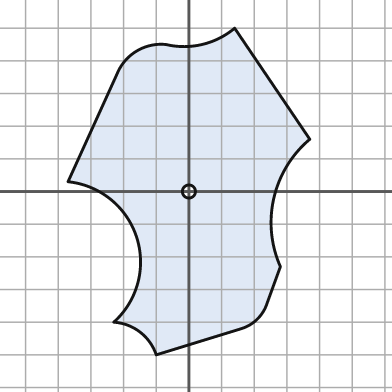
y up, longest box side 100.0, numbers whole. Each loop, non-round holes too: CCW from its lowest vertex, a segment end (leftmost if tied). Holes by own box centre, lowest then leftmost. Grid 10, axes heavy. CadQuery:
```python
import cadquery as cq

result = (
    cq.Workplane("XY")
    .moveTo(-10.0, -50.0)
    .lineTo(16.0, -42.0)
    .threePointArc((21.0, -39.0), (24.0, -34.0))
    .lineTo(28.0, -23.0)
    .threePointArc((26.0, -2.0), (37.0, 16.0))
    .lineTo(14.0, 50.0)
    .threePointArc((4.0, 45.0), (-7.0, 45.0))
    .threePointArc((-16.0, 43.0), (-22.0, 36.0))
    .lineTo(-37.0, 3.0)
    .threePointArc((-16.0, -14.0), (-23.0, -40.0))
    .threePointArc((-15.0, -43.0), (-10.0, -50.0))
    .close()
    .moveTo(0.0, 0.0)
    .circle(2.0)
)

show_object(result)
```